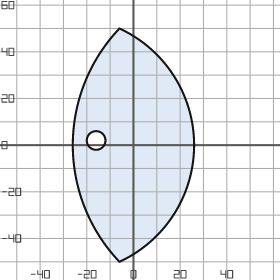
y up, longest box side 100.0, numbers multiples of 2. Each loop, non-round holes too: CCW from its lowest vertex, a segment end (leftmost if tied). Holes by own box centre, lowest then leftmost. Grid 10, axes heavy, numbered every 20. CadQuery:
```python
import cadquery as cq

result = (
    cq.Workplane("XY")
    .moveTo(-6.0, -50.0)
    .threePointArc((26.0, 0.0), (-6.0, 50.0))
    .threePointArc((-26.0, 0.0), (-6.0, -50.0))
    .close()
    .moveTo(-16.0, 2.0)
    .circle(4.0)
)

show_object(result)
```